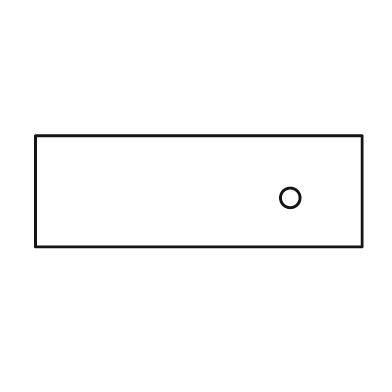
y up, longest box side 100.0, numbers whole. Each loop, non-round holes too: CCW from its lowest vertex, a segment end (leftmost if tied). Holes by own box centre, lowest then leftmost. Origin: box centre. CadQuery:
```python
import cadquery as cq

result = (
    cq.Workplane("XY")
    .moveTo(-50.0, -17.0)
    .lineTo(50.0, -17.0)
    .lineTo(50.0, 17.0)
    .lineTo(-50.0, 17.0)
    .close()
    .moveTo(28.0, -2.0)
    .circle(3.0)
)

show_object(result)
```